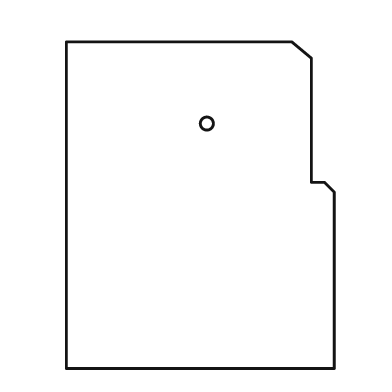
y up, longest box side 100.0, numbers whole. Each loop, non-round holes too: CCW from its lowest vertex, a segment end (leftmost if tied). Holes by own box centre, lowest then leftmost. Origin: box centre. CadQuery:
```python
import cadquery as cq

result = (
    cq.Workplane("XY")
    .moveTo(-41.0, -50.0)
    .lineTo(41.0, -50.0)
    .lineTo(41.0, 4.0)
    .lineTo(38.0, 7.0)
    .lineTo(34.0, 7.0)
    .lineTo(34.0, 45.0)
    .lineTo(28.0, 50.0)
    .lineTo(-41.0, 50.0)
    .close()
    .moveTo(2.0, 25.0)
    .circle(2.0)
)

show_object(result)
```